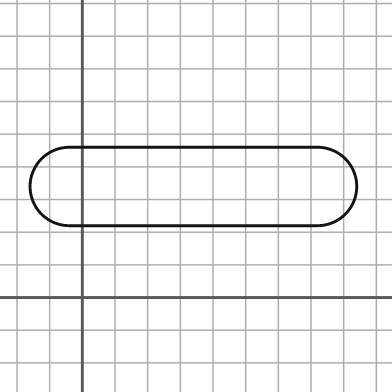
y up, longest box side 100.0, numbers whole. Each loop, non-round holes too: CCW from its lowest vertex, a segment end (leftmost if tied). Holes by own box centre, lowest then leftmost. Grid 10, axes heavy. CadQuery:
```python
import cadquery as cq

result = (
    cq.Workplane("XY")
    .moveTo(-4.0, 22.0)
    .lineTo(72.0, 22.0)
    .threePointArc((84.0, 34.0), (72.0, 46.0))
    .lineTo(-4.0, 46.0)
    .threePointArc((-16.0, 34.0), (-4.0, 22.0))
    .close()
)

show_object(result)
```